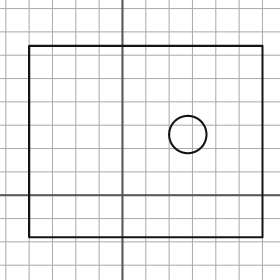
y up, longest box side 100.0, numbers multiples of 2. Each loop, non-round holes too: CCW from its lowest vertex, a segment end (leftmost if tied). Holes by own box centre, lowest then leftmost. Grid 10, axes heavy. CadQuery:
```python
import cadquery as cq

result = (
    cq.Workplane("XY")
    .moveTo(-40.0, -18.0)
    .lineTo(60.0, -18.0)
    .lineTo(60.0, 64.0)
    .lineTo(-40.0, 64.0)
    .close()
    .moveTo(28.0, 26.0)
    .circle(8.0)
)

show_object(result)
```